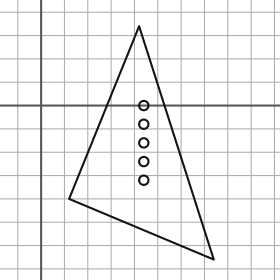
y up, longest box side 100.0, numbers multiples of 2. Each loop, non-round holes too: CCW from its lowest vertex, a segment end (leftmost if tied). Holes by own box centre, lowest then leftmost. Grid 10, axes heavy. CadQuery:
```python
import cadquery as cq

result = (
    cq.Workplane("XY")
    .moveTo(74.0, -66.0)
    .lineTo(42.0, 34.0)
    .lineTo(12.0, -40.0)
    .close()
    .moveTo(44.0, -32.0)
    .circle(2.0)
    .moveTo(44.0, -24.0)
    .circle(2.0)
    .moveTo(44.0, -16.0)
    .circle(2.0)
    .moveTo(44.0, -8.0)
    .circle(2.0)
    .moveTo(44.0, 0.0)
    .circle(2.0)
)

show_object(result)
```